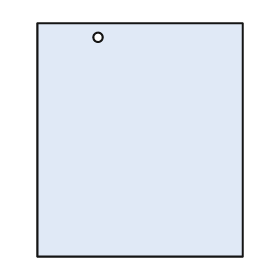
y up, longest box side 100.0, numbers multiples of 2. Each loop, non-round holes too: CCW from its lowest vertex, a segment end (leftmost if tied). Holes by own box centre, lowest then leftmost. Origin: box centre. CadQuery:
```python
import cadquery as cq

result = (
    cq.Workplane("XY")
    .moveTo(-44.0, -50.0)
    .lineTo(44.0, -50.0)
    .lineTo(44.0, 50.0)
    .lineTo(-44.0, 50.0)
    .close()
    .moveTo(-18.0, 44.0)
    .circle(2.0)
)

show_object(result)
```